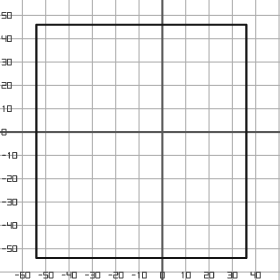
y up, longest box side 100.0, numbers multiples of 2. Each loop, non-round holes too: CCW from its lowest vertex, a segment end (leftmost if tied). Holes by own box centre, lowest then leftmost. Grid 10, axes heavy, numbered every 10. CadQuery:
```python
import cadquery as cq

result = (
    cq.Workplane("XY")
    .moveTo(-54.0, -54.0)
    .lineTo(36.0, -54.0)
    .lineTo(36.0, 46.0)
    .lineTo(-54.0, 46.0)
    .close()
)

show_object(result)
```